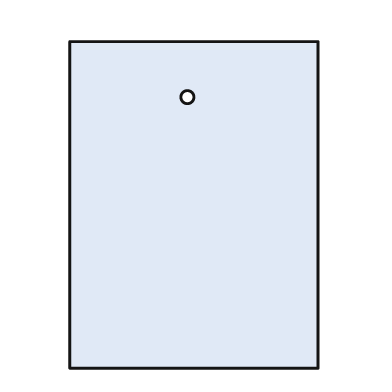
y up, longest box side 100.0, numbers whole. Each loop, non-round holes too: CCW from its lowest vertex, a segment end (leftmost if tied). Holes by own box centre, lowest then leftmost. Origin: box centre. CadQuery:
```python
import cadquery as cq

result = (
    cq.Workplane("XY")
    .moveTo(-38.0, -50.0)
    .lineTo(38.0, -50.0)
    .lineTo(38.0, 50.0)
    .lineTo(-38.0, 50.0)
    .close()
    .moveTo(-2.0, 33.0)
    .circle(2.0)
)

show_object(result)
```